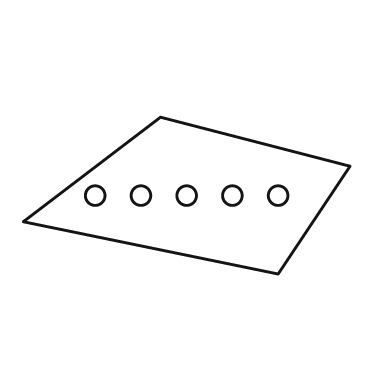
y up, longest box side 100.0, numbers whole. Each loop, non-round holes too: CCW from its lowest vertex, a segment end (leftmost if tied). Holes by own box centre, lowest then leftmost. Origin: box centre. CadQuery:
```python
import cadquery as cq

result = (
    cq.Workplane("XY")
    .moveTo(28.0, -24.0)
    .lineTo(50.0, 9.0)
    .lineTo(-8.0, 24.0)
    .lineTo(-50.0, -8.0)
    .close()
    .moveTo(-28.0, 0.0)
    .circle(3.0)
    .moveTo(-14.0, 0.0)
    .circle(3.0)
    .moveTo(0.0, 0.0)
    .circle(3.0)
    .moveTo(14.0, 0.0)
    .circle(3.0)
    .moveTo(28.0, 0.0)
    .circle(3.0)
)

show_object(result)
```